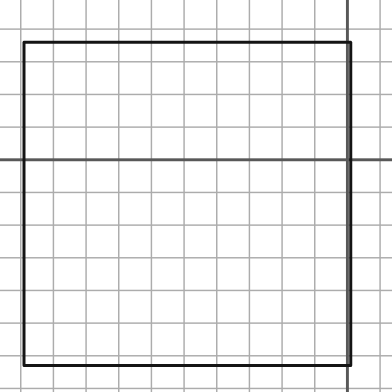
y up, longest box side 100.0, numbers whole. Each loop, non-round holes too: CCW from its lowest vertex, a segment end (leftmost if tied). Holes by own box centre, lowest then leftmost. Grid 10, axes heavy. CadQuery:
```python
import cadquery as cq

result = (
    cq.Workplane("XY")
    .moveTo(-99.0, -63.0)
    .lineTo(1.0, -63.0)
    .lineTo(1.0, 36.0)
    .lineTo(-99.0, 36.0)
    .close()
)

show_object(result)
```